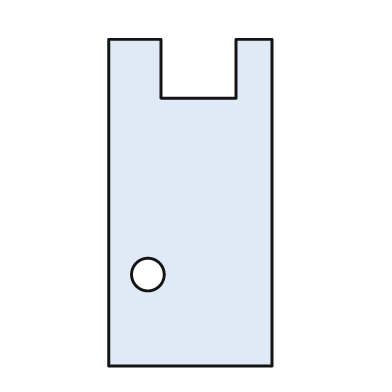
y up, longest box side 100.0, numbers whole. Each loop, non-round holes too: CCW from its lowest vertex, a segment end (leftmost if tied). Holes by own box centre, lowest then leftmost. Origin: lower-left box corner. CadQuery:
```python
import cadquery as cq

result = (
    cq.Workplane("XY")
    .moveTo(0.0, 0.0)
    .lineTo(50.0, 0.0)
    .lineTo(50.0, 100.0)
    .lineTo(39.0, 100.0)
    .lineTo(39.0, 82.0)
    .lineTo(16.0, 82.0)
    .lineTo(16.0, 100.0)
    .lineTo(0.0, 100.0)
    .close()
    .moveTo(12.0, 28.0)
    .circle(5.0)
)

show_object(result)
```